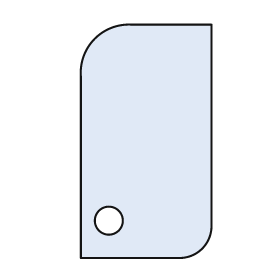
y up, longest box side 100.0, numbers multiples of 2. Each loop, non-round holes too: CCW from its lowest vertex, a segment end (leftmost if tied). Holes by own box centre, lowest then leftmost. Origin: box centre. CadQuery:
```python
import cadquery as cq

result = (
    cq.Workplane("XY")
    .moveTo(-28.0, -50.0)
    .lineTo(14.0, -50.0)
    .threePointArc((24.0, -46.0), (28.0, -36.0))
    .lineTo(28.0, 50.0)
    .lineTo(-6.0, 50.0)
    .threePointArc((-22.0, 44.0), (-28.0, 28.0))
    .close()
    .moveTo(-16.0, -34.0)
    .circle(6.0)
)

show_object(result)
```